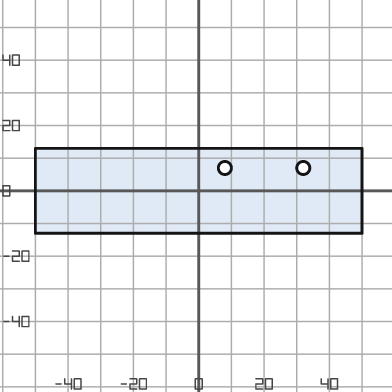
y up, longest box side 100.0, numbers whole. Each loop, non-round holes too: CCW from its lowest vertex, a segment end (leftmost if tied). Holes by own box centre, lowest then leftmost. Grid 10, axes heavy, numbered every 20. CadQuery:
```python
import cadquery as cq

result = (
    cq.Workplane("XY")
    .moveTo(-50.0, -13.0)
    .lineTo(50.0, -13.0)
    .lineTo(50.0, 13.0)
    .lineTo(-50.0, 13.0)
    .close()
    .moveTo(8.0, 7.0)
    .circle(2.0)
    .moveTo(32.0, 7.0)
    .circle(2.0)
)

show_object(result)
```